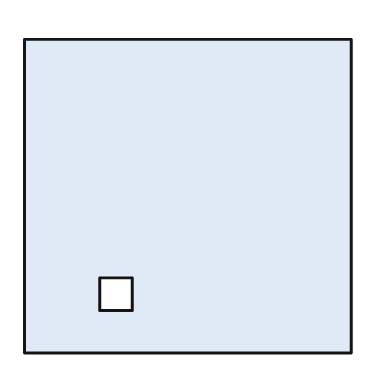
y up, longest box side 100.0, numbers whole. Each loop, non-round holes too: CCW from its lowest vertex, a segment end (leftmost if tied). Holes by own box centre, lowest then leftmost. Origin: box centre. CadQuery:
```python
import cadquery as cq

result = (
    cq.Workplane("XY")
    .moveTo(-50.0, -48.0)
    .lineTo(50.0, -48.0)
    .lineTo(50.0, 48.0)
    .lineTo(-50.0, 48.0)
    .close()
    .moveTo(-27.0, -35.0)
    .lineTo(-17.0, -35.0)
    .lineTo(-17.0, -25.0)
    .lineTo(-27.0, -25.0)
    .close()
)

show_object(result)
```